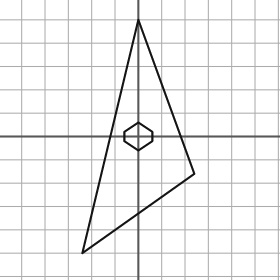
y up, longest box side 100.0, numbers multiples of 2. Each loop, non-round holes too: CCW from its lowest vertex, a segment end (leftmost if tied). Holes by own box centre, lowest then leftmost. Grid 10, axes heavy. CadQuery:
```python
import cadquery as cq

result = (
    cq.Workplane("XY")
    .moveTo(-24.0, -50.0)
    .lineTo(24.0, -16.0)
    .lineTo(0.0, 50.0)
    .close()
    .moveTo(0.0, -6.0)
    .lineTo(6.0, -2.0)
    .lineTo(6.0, 2.0)
    .lineTo(0.0, 6.0)
    .lineTo(-6.0, 2.0)
    .lineTo(-6.0, -2.0)
    .close()
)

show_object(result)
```